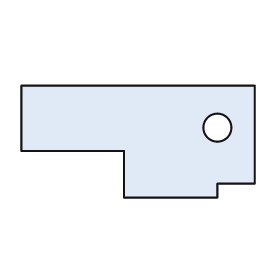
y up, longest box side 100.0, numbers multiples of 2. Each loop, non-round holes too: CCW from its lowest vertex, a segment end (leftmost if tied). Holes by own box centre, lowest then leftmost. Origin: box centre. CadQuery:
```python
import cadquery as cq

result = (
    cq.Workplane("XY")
    .moveTo(-6.0, -24.0)
    .lineTo(34.0, -24.0)
    .lineTo(34.0, -18.0)
    .lineTo(50.0, -18.0)
    .lineTo(50.0, 24.0)
    .lineTo(-50.0, 24.0)
    .lineTo(-50.0, -4.0)
    .lineTo(-6.0, -4.0)
    .close()
    .moveTo(34.0, 6.0)
    .circle(6.0)
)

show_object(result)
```